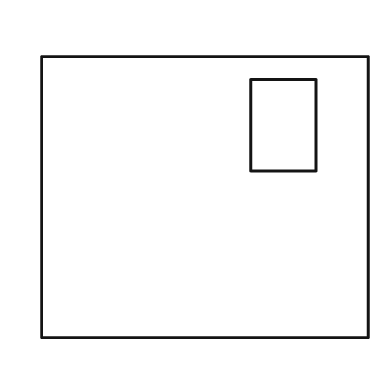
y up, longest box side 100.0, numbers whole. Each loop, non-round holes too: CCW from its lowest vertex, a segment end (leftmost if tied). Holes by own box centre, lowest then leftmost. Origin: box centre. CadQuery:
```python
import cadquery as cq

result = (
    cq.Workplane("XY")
    .moveTo(-50.0, -43.0)
    .lineTo(50.0, -43.0)
    .lineTo(50.0, 43.0)
    .lineTo(-50.0, 43.0)
    .close()
    .moveTo(14.0, 8.0)
    .lineTo(34.0, 8.0)
    .lineTo(34.0, 36.0)
    .lineTo(14.0, 36.0)
    .close()
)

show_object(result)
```